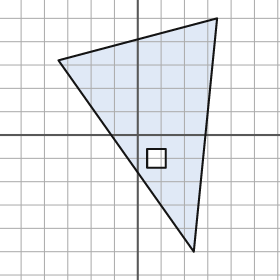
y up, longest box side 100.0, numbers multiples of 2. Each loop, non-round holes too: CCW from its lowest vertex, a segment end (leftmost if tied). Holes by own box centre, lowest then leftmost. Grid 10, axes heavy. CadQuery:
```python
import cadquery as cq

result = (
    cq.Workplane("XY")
    .moveTo(24.0, -50.0)
    .lineTo(34.0, 50.0)
    .lineTo(-34.0, 32.0)
    .close()
    .moveTo(4.0, -14.0)
    .lineTo(12.0, -14.0)
    .lineTo(12.0, -6.0)
    .lineTo(4.0, -6.0)
    .close()
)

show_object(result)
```